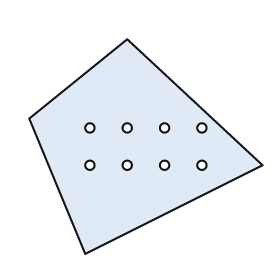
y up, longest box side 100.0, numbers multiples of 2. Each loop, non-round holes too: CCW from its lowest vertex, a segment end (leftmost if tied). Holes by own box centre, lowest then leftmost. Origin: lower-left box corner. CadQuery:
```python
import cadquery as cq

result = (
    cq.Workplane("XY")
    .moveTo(24.0, 0.0)
    .lineTo(100.0, 38.0)
    .lineTo(42.0, 92.0)
    .lineTo(0.0, 58.0)
    .close()
    .moveTo(26.0, 38.0)
    .circle(2.0)
    .moveTo(42.0, 38.0)
    .circle(2.0)
    .moveTo(58.0, 38.0)
    .circle(2.0)
    .moveTo(74.0, 38.0)
    .circle(2.0)
    .moveTo(26.0, 54.0)
    .circle(2.0)
    .moveTo(42.0, 54.0)
    .circle(2.0)
    .moveTo(58.0, 54.0)
    .circle(2.0)
    .moveTo(74.0, 54.0)
    .circle(2.0)
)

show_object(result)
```